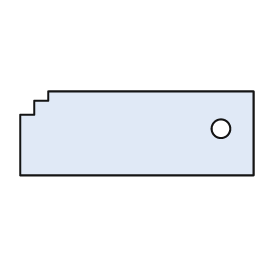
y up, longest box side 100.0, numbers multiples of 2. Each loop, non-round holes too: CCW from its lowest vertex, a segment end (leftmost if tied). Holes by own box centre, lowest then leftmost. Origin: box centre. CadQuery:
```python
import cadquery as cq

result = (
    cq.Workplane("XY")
    .moveTo(-50.0, -18.0)
    .lineTo(50.0, -18.0)
    .lineTo(50.0, 18.0)
    .lineTo(-38.0, 18.0)
    .lineTo(-38.0, 14.0)
    .lineTo(-44.0, 14.0)
    .lineTo(-44.0, 8.0)
    .lineTo(-50.0, 8.0)
    .close()
    .moveTo(36.0, 2.0)
    .circle(4.0)
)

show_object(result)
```